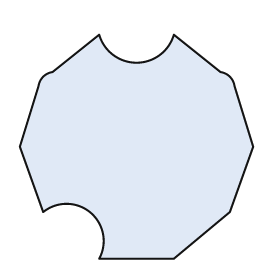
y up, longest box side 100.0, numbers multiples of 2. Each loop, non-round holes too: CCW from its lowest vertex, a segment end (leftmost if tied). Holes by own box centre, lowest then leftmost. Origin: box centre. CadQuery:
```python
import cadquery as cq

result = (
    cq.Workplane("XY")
    .moveTo(-16.0, -48.0)
    .lineTo(16.0, -48.0)
    .lineTo(40.0, -28.0)
    .lineTo(50.0, 0.0)
    .lineTo(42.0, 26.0)
    .threePointArc((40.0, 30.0), (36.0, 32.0))
    .lineTo(16.0, 48.0)
    .threePointArc((0.0, 36.0), (-16.0, 48.0))
    .lineTo(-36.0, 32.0)
    .threePointArc((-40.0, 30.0), (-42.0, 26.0))
    .lineTo(-50.0, 0.0)
    .lineTo(-40.0, -28.0)
    .threePointArc((-20.0, -28.0), (-16.0, -48.0))
    .close()
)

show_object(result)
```